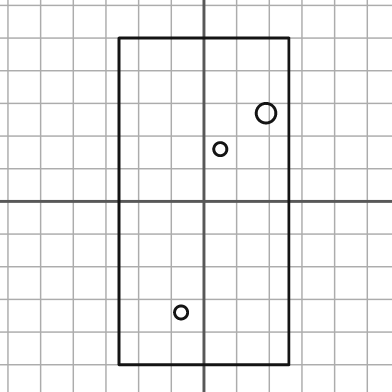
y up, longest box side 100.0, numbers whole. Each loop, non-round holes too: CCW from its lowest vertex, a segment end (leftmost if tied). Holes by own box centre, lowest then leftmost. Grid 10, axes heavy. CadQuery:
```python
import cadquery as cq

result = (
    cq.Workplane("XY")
    .moveTo(-26.0, -50.0)
    .lineTo(26.0, -50.0)
    .lineTo(26.0, 50.0)
    .lineTo(-26.0, 50.0)
    .close()
    .moveTo(-7.0, -34.0)
    .circle(2.0)
    .moveTo(5.0, 16.0)
    .circle(2.0)
    .moveTo(19.0, 27.0)
    .circle(3.0)
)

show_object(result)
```